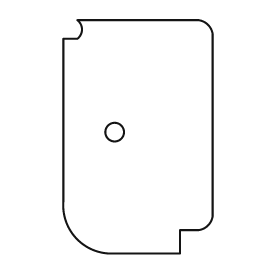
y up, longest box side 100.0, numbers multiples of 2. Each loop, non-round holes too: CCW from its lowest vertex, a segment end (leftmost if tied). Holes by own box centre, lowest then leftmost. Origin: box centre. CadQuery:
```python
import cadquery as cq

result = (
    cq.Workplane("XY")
    .moveTo(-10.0, -50.0)
    .lineTo(18.0, -50.0)
    .lineTo(18.0, -40.0)
    .lineTo(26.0, -40.0)
    .threePointArc((30.0, -38.0), (32.0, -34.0))
    .lineTo(32.0, 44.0)
    .threePointArc((30.0, 48.0), (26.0, 50.0))
    .lineTo(-26.0, 50.0)
    .threePointArc((-24.0, 46.0), (-26.0, 42.0))
    .lineTo(-32.0, 42.0)
    .lineTo(-32.0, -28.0)
    .threePointArc((-26.0, -44.0), (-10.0, -50.0))
    .close()
    .moveTo(-10.0, 2.0)
    .circle(4.0)
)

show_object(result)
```